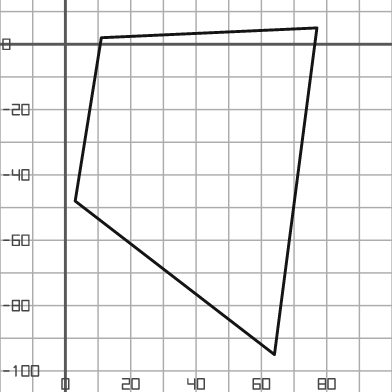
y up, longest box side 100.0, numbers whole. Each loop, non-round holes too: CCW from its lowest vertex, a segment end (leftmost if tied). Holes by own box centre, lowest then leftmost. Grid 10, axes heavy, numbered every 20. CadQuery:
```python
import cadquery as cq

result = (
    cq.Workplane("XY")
    .moveTo(64.0, -95.0)
    .lineTo(77.0, 5.0)
    .lineTo(11.0, 2.0)
    .lineTo(3.0, -48.0)
    .close()
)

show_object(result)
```